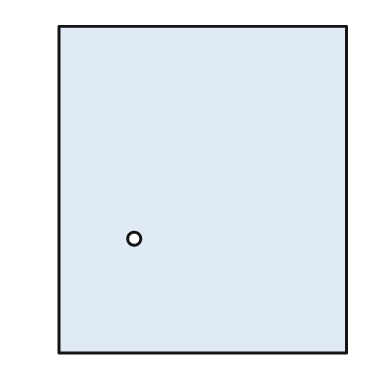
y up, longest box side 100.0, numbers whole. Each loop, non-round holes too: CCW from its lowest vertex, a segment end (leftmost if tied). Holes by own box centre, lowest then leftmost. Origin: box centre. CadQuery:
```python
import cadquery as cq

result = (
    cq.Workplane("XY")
    .moveTo(-44.0, -50.0)
    .lineTo(44.0, -50.0)
    .lineTo(44.0, 50.0)
    .lineTo(-44.0, 50.0)
    .close()
    .moveTo(-21.0, -15.0)
    .circle(2.0)
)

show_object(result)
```